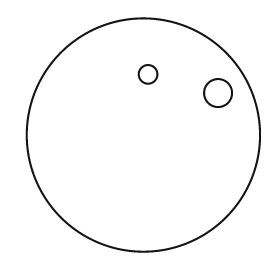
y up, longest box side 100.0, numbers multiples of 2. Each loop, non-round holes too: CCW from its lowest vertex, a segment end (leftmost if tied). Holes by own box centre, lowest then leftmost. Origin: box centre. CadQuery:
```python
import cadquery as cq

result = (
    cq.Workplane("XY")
    .moveTo(0.0, 0.0)
    .circle(50.0)
    .moveTo(32.0, 18.0)
    .circle(6.0)
    .moveTo(2.0, 26.0)
    .circle(4.0)
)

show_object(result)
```